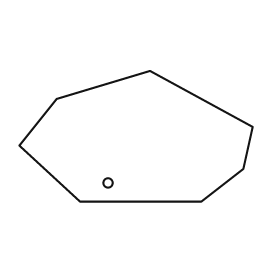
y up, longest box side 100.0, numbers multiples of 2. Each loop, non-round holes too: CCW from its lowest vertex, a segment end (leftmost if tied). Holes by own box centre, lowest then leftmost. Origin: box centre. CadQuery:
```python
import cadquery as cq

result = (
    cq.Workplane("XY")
    .moveTo(-24.0, -28.0)
    .lineTo(28.0, -28.0)
    .lineTo(46.0, -14.0)
    .lineTo(50.0, 4.0)
    .lineTo(6.0, 28.0)
    .lineTo(-34.0, 16.0)
    .lineTo(-50.0, -4.0)
    .close()
    .moveTo(-12.0, -20.0)
    .circle(2.0)
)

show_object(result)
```